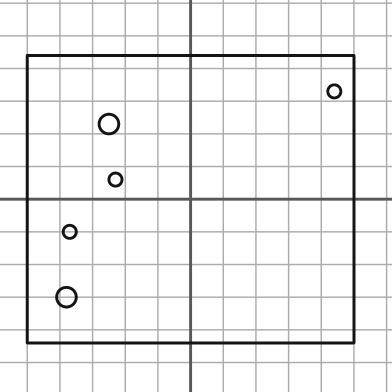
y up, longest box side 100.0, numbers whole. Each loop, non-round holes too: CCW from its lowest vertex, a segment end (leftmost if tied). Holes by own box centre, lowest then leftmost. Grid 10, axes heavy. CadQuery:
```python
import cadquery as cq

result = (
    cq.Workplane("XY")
    .moveTo(-50.0, -44.0)
    .lineTo(50.0, -44.0)
    .lineTo(50.0, 44.0)
    .lineTo(-50.0, 44.0)
    .close()
    .moveTo(-38.0, -30.0)
    .circle(3.0)
    .moveTo(-37.0, -10.0)
    .circle(2.0)
    .moveTo(-23.0, 6.0)
    .circle(2.0)
    .moveTo(-25.0, 23.0)
    .circle(3.0)
    .moveTo(44.0, 33.0)
    .circle(2.0)
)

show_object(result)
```